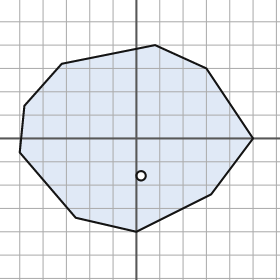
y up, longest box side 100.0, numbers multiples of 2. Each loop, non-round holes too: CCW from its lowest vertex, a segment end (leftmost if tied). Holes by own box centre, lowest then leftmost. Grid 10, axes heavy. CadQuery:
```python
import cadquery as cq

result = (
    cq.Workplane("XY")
    .moveTo(0.0, -40.0)
    .lineTo(32.0, -24.0)
    .lineTo(50.0, 0.0)
    .lineTo(30.0, 30.0)
    .lineTo(8.0, 40.0)
    .lineTo(-32.0, 32.0)
    .lineTo(-48.0, 14.0)
    .lineTo(-50.0, -6.0)
    .lineTo(-26.0, -34.0)
    .close()
    .moveTo(2.0, -16.0)
    .circle(2.0)
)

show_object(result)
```